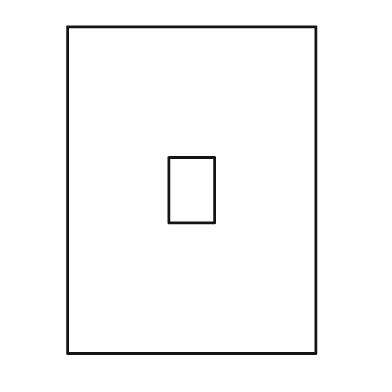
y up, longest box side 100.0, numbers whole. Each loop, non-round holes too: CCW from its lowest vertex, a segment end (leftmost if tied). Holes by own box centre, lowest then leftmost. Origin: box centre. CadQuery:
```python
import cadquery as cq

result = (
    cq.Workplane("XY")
    .moveTo(-38.0, -50.0)
    .lineTo(38.0, -50.0)
    .lineTo(38.0, 50.0)
    .lineTo(-38.0, 50.0)
    .close()
    .moveTo(-7.0, -10.0)
    .lineTo(7.0, -10.0)
    .lineTo(7.0, 10.0)
    .lineTo(-7.0, 10.0)
    .close()
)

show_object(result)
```